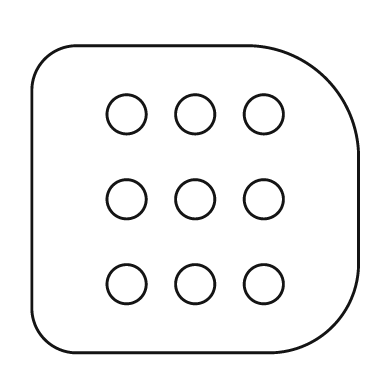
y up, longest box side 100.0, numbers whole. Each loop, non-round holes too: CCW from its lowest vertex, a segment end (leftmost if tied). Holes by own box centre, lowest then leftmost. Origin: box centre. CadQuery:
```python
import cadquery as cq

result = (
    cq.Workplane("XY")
    .moveTo(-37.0, -47.0)
    .lineTo(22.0, -47.0)
    .threePointArc((42.0, -39.0), (50.0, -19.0))
    .lineTo(50.0, 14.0)
    .threePointArc((40.0, 37.0), (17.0, 47.0))
    .lineTo(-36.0, 47.0)
    .threePointArc((-46.0, 43.0), (-50.0, 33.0))
    .lineTo(-50.0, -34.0)
    .threePointArc((-46.0, -43.0), (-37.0, -47.0))
    .close()
    .moveTo(-21.0, -26.0)
    .circle(6.0)
    .moveTo(0.0, -26.0)
    .circle(6.0)
    .moveTo(21.0, -26.0)
    .circle(6.0)
    .moveTo(-21.0, 0.0)
    .circle(6.0)
    .moveTo(0.0, 0.0)
    .circle(6.0)
    .moveTo(21.0, 0.0)
    .circle(6.0)
    .moveTo(-21.0, 26.0)
    .circle(6.0)
    .moveTo(0.0, 26.0)
    .circle(6.0)
    .moveTo(21.0, 26.0)
    .circle(6.0)
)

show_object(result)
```